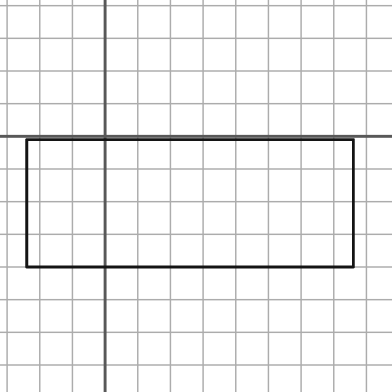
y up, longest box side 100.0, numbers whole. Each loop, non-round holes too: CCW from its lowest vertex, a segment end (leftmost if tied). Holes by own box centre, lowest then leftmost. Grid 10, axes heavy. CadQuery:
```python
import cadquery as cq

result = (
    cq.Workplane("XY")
    .moveTo(-24.0, -40.0)
    .lineTo(76.0, -40.0)
    .lineTo(76.0, -1.0)
    .lineTo(-24.0, -1.0)
    .close()
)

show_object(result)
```